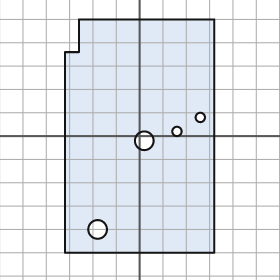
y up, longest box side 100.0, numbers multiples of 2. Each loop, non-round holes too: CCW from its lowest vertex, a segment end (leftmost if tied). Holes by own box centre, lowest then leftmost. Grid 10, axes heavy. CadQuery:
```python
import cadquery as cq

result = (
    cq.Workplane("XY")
    .moveTo(-32.0, -50.0)
    .lineTo(32.0, -50.0)
    .lineTo(32.0, 50.0)
    .lineTo(-26.0, 50.0)
    .lineTo(-26.0, 36.0)
    .lineTo(-32.0, 36.0)
    .close()
    .moveTo(-18.0, -40.0)
    .circle(4.0)
    .moveTo(2.0, -2.0)
    .circle(4.0)
    .moveTo(16.0, 2.0)
    .circle(2.0)
    .moveTo(26.0, 8.0)
    .circle(2.0)
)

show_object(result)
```